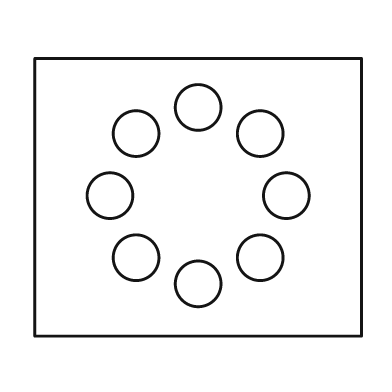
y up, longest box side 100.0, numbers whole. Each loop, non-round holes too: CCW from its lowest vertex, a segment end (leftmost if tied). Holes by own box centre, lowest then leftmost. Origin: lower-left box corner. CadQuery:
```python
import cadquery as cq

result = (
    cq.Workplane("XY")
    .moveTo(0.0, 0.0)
    .lineTo(100.0, 0.0)
    .lineTo(100.0, 85.0)
    .lineTo(0.0, 85.0)
    .close()
    .moveTo(50.0, 16.0)
    .circle(7.0)
    .moveTo(31.0, 24.0)
    .circle(7.0)
    .moveTo(69.0, 24.0)
    .circle(7.0)
    .moveTo(23.0, 43.0)
    .circle(7.0)
    .moveTo(77.0, 43.0)
    .circle(7.0)
    .moveTo(31.0, 62.0)
    .circle(7.0)
    .moveTo(69.0, 62.0)
    .circle(7.0)
    .moveTo(50.0, 70.0)
    .circle(7.0)
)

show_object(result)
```